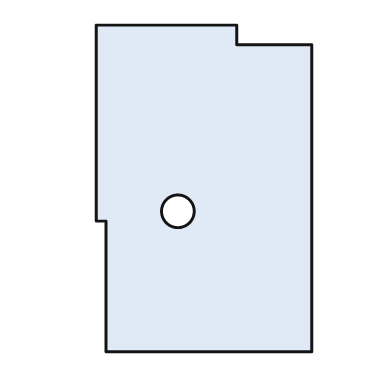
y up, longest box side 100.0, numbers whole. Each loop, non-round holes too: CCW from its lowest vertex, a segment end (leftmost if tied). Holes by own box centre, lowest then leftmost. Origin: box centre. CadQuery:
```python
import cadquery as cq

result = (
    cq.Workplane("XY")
    .moveTo(-30.0, -50.0)
    .lineTo(33.0, -50.0)
    .lineTo(33.0, 44.0)
    .lineTo(10.0, 44.0)
    .lineTo(10.0, 50.0)
    .lineTo(-33.0, 50.0)
    .lineTo(-33.0, -10.0)
    .lineTo(-30.0, -10.0)
    .close()
    .moveTo(-8.0, -7.0)
    .circle(5.0)
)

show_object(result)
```